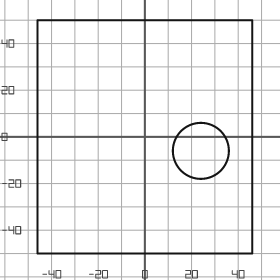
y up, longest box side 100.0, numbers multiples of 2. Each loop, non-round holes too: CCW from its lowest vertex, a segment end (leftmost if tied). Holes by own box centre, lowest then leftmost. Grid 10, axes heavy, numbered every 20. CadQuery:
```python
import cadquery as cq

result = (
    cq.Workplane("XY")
    .moveTo(-46.0, -50.0)
    .lineTo(46.0, -50.0)
    .lineTo(46.0, 50.0)
    .lineTo(-46.0, 50.0)
    .close()
    .moveTo(24.0, -6.0)
    .circle(12.0)
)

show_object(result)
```